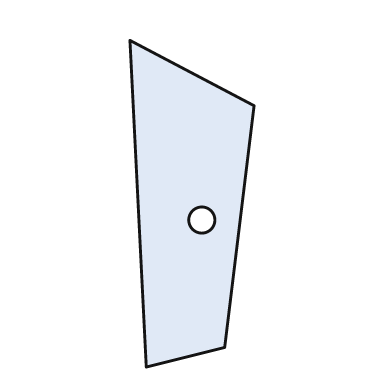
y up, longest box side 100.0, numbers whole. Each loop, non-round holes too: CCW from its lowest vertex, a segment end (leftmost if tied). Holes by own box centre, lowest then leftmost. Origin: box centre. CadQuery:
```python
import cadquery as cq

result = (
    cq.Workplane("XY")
    .moveTo(-14.0, -50.0)
    .lineTo(10.0, -44.0)
    .lineTo(19.0, 30.0)
    .lineTo(-19.0, 50.0)
    .close()
    .moveTo(3.0, -5.0)
    .circle(4.0)
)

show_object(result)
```